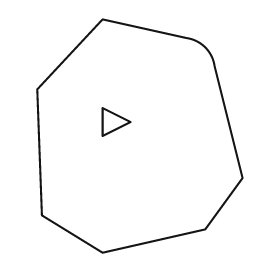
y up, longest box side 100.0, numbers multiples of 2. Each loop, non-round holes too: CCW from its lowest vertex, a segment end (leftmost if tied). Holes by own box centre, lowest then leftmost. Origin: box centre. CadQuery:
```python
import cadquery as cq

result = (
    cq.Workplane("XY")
    .moveTo(-16.0, -50.0)
    .lineTo(28.0, -40.0)
    .lineTo(44.0, -18.0)
    .lineTo(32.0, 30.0)
    .threePointArc((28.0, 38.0), (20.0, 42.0))
    .lineTo(-16.0, 50.0)
    .lineTo(-44.0, 20.0)
    .lineTo(-42.0, -34.0)
    .close()
    .moveTo(-16.0, 0.0)
    .lineTo(-4.0, 6.0)
    .lineTo(-16.0, 12.0)
    .close()
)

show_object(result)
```